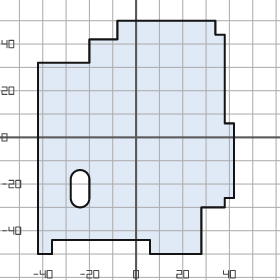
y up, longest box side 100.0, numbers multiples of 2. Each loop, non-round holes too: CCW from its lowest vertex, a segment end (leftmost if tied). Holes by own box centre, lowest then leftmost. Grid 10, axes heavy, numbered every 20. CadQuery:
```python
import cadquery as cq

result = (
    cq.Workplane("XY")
    .moveTo(-42.0, -50.0)
    .lineTo(-36.0, -50.0)
    .lineTo(-36.0, -44.0)
    .lineTo(6.0, -44.0)
    .lineTo(6.0, -50.0)
    .lineTo(28.0, -50.0)
    .lineTo(28.0, -30.0)
    .lineTo(38.0, -30.0)
    .lineTo(38.0, -26.0)
    .lineTo(42.0, -26.0)
    .lineTo(42.0, 6.0)
    .lineTo(38.0, 6.0)
    .lineTo(38.0, 44.0)
    .lineTo(34.0, 44.0)
    .lineTo(34.0, 50.0)
    .lineTo(-8.0, 50.0)
    .lineTo(-8.0, 42.0)
    .lineTo(-20.0, 42.0)
    .lineTo(-20.0, 32.0)
    .lineTo(-42.0, 32.0)
    .close()
    .moveTo(-28.0, -26.0)
    .threePointArc((-24.0, -30.0), (-20.0, -26.0))
    .lineTo(-20.0, -18.0)
    .threePointArc((-24.0, -14.0), (-28.0, -18.0))
    .close()
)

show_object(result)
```